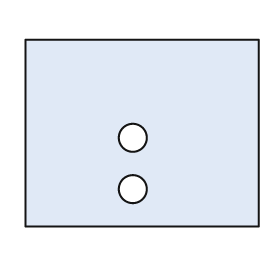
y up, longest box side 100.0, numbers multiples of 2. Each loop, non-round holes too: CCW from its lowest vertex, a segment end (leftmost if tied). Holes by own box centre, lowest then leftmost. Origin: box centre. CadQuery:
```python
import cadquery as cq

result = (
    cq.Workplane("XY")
    .moveTo(-50.0, -40.0)
    .lineTo(50.0, -40.0)
    .lineTo(50.0, 40.0)
    .lineTo(-50.0, 40.0)
    .close()
    .moveTo(-4.0, -24.0)
    .circle(6.0)
    .moveTo(-4.0, -2.0)
    .circle(6.0)
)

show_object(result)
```